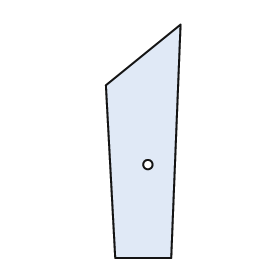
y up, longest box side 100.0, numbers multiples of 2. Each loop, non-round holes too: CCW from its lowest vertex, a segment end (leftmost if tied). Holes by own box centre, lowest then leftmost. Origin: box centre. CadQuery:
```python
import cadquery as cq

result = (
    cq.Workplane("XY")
    .moveTo(-12.0, -50.0)
    .lineTo(12.0, -50.0)
    .lineTo(16.0, 50.0)
    .lineTo(-16.0, 24.0)
    .close()
    .moveTo(2.0, -10.0)
    .circle(2.0)
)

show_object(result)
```